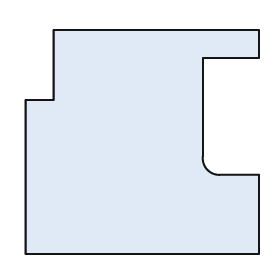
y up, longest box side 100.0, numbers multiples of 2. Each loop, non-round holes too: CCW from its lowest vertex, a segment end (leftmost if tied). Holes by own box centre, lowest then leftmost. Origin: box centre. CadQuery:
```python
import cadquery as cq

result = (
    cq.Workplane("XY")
    .moveTo(-50.0, -48.0)
    .lineTo(50.0, -48.0)
    .lineTo(50.0, -14.0)
    .lineTo(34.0, -14.0)
    .threePointArc((28.0, -12.0), (26.0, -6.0))
    .lineTo(26.0, 36.0)
    .lineTo(50.0, 36.0)
    .lineTo(50.0, 48.0)
    .lineTo(-38.0, 48.0)
    .lineTo(-38.0, 18.0)
    .lineTo(-50.0, 18.0)
    .close()
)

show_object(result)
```